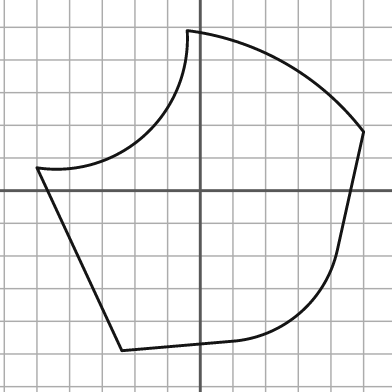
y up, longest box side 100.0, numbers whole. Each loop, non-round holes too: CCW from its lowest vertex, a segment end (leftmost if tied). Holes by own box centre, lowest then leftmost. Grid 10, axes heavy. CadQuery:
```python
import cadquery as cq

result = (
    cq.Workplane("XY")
    .moveTo(-24.0, -49.0)
    .lineTo(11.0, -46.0)
    .threePointArc((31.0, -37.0), (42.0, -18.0))
    .lineTo(50.0, 18.0)
    .threePointArc((26.0, 39.0), (-4.0, 49.0))
    .threePointArc((-17.0, 17.0), (-50.0, 7.0))
    .close()
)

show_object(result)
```